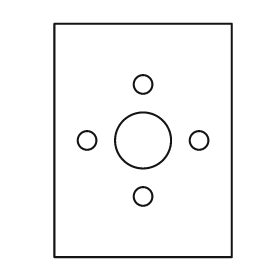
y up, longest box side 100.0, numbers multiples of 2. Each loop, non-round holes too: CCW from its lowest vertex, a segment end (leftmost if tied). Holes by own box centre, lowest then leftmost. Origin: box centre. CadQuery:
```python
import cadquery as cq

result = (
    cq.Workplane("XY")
    .moveTo(-38.0, -50.0)
    .lineTo(38.0, -50.0)
    .lineTo(38.0, 50.0)
    .lineTo(-38.0, 50.0)
    .close()
    .moveTo(0.0, -24.0)
    .circle(4.0)
    .moveTo(-24.0, 0.0)
    .circle(4.0)
    .moveTo(0.0, 0.0)
    .circle(12.0)
    .moveTo(24.0, 0.0)
    .circle(4.0)
    .moveTo(0.0, 24.0)
    .circle(4.0)
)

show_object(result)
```